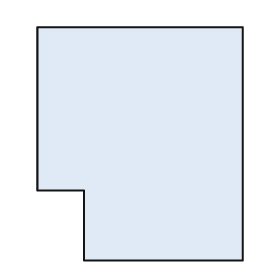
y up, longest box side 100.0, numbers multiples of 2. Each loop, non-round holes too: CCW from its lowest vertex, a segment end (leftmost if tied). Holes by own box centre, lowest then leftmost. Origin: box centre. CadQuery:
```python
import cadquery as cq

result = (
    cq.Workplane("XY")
    .moveTo(-24.0, -50.0)
    .lineTo(44.0, -50.0)
    .lineTo(44.0, 50.0)
    .lineTo(-44.0, 50.0)
    .lineTo(-44.0, -20.0)
    .lineTo(-24.0, -20.0)
    .close()
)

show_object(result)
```